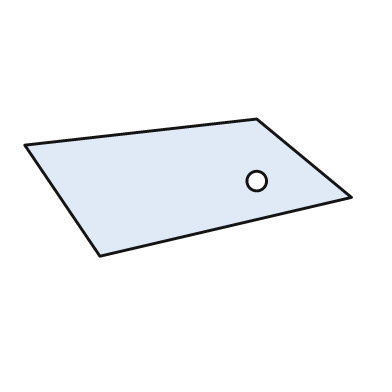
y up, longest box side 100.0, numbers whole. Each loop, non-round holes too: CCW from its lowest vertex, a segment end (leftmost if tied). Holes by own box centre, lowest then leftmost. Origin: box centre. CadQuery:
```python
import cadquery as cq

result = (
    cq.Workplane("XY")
    .moveTo(-27.0, -21.0)
    .lineTo(50.0, -3.0)
    .lineTo(21.0, 21.0)
    .lineTo(-50.0, 13.0)
    .close()
    .moveTo(21.0, 2.0)
    .circle(3.0)
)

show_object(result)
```